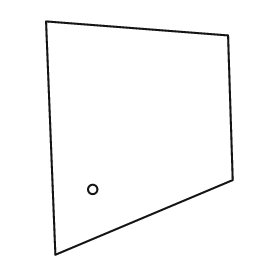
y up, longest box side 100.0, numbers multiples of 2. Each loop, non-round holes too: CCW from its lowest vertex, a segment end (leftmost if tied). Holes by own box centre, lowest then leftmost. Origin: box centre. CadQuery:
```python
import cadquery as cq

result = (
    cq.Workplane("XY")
    .moveTo(-36.0, -50.0)
    .lineTo(40.0, -18.0)
    .lineTo(38.0, 44.0)
    .lineTo(-40.0, 50.0)
    .close()
    .moveTo(-20.0, -22.0)
    .circle(2.0)
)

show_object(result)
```